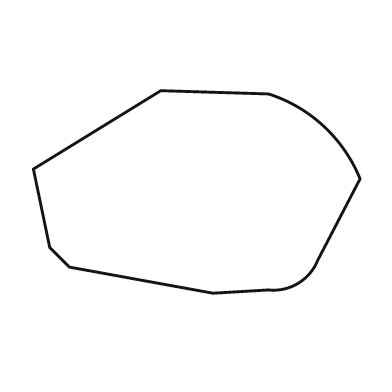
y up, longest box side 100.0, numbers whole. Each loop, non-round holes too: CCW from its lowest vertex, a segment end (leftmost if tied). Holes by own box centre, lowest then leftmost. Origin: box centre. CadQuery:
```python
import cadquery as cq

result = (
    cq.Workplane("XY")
    .moveTo(5.0, -31.0)
    .lineTo(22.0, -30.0)
    .threePointArc((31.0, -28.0), (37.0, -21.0))
    .lineTo(50.0, 4.0)
    .threePointArc((39.0, 20.0), (22.0, 30.0))
    .lineTo(-11.0, 31.0)
    .lineTo(-50.0, 7.0)
    .lineTo(-45.0, -17.0)
    .lineTo(-39.0, -23.0)
    .close()
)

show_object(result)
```